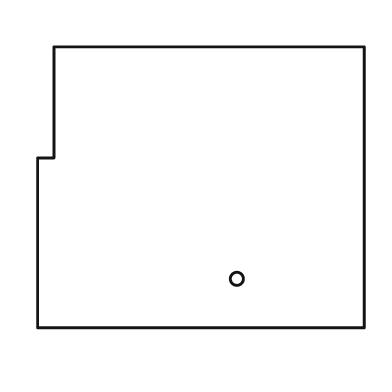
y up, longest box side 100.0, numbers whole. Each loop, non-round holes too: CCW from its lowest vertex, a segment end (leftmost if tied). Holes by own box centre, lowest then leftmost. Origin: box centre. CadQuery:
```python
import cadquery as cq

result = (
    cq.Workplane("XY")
    .moveTo(-50.0, -43.0)
    .lineTo(50.0, -43.0)
    .lineTo(50.0, 43.0)
    .lineTo(-45.0, 43.0)
    .lineTo(-45.0, 9.0)
    .lineTo(-50.0, 9.0)
    .close()
    .moveTo(11.0, -28.0)
    .circle(2.0)
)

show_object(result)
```